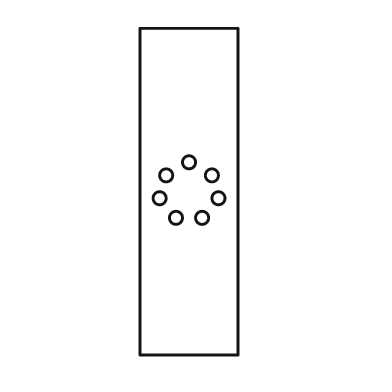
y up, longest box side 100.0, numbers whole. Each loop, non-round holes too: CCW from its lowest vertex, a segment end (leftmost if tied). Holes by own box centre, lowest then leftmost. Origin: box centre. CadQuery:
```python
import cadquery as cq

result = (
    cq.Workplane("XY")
    .moveTo(-15.0, -50.0)
    .lineTo(15.0, -50.0)
    .lineTo(15.0, 50.0)
    .lineTo(-15.0, 50.0)
    .close()
    .moveTo(-4.0, -8.0)
    .circle(2.0)
    .moveTo(4.0, -8.0)
    .circle(2.0)
    .moveTo(-9.0, -2.0)
    .circle(2.0)
    .moveTo(9.0, -2.0)
    .circle(2.0)
    .moveTo(-7.0, 5.0)
    .circle(2.0)
    .moveTo(7.0, 5.0)
    .circle(2.0)
    .moveTo(0.0, 9.0)
    .circle(2.0)
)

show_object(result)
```